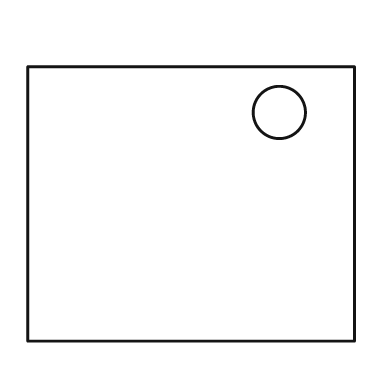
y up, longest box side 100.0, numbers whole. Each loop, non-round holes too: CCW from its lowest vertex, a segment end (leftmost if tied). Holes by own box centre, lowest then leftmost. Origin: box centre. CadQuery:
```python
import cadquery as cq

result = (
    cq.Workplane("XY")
    .moveTo(-50.0, -42.0)
    .lineTo(50.0, -42.0)
    .lineTo(50.0, 42.0)
    .lineTo(-50.0, 42.0)
    .close()
    .moveTo(27.0, 28.0)
    .circle(8.0)
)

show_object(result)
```